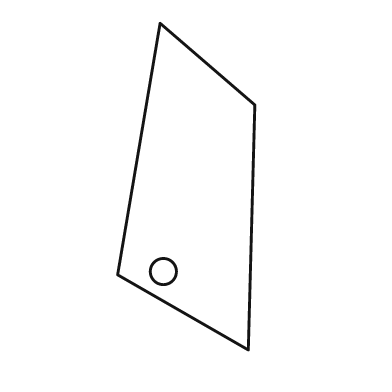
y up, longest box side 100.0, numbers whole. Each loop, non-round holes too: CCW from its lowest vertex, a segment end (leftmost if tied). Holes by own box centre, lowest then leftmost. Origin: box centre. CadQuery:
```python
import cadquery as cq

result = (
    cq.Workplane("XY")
    .moveTo(19.0, -50.0)
    .lineTo(21.0, 25.0)
    .lineTo(-8.0, 50.0)
    .lineTo(-21.0, -27.0)
    .close()
    .moveTo(-7.0, -26.0)
    .circle(4.0)
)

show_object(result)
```